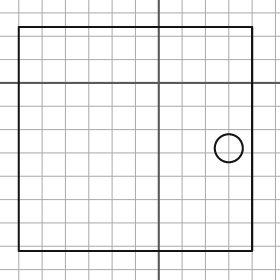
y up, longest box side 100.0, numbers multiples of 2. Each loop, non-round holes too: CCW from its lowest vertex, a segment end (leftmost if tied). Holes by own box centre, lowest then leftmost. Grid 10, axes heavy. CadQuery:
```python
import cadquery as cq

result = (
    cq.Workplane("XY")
    .moveTo(-60.0, -72.0)
    .lineTo(40.0, -72.0)
    .lineTo(40.0, 24.0)
    .lineTo(-60.0, 24.0)
    .close()
    .moveTo(30.0, -28.0)
    .circle(6.0)
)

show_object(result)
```